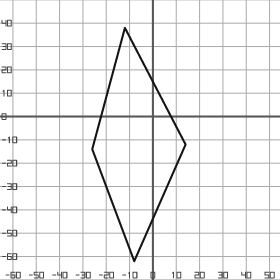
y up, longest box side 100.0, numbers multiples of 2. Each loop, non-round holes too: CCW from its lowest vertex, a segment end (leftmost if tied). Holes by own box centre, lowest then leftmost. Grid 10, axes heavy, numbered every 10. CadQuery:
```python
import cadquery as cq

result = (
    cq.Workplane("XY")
    .moveTo(-8.0, -62.0)
    .lineTo(14.0, -12.0)
    .lineTo(-12.0, 38.0)
    .lineTo(-26.0, -14.0)
    .close()
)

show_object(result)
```